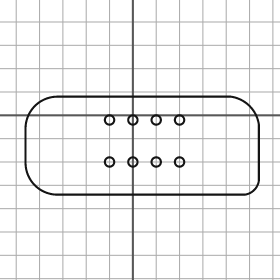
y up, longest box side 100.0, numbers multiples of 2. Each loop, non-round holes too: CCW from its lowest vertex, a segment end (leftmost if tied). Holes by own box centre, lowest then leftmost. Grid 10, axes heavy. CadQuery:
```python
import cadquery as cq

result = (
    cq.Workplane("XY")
    .moveTo(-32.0, -34.0)
    .lineTo(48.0, -34.0)
    .threePointArc((52.0, -32.0), (54.0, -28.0))
    .lineTo(54.0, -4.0)
    .threePointArc((50.0, 4.0), (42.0, 8.0))
    .lineTo(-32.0, 8.0)
    .threePointArc((-42.0, 4.0), (-46.0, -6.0))
    .lineTo(-46.0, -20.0)
    .threePointArc((-42.0, -30.0), (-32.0, -34.0))
    .close()
    .moveTo(-10.0, -20.0)
    .circle(2.0)
    .moveTo(0.0, -20.0)
    .circle(2.0)
    .moveTo(10.0, -20.0)
    .circle(2.0)
    .moveTo(20.0, -20.0)
    .circle(2.0)
    .moveTo(-10.0, -2.0)
    .circle(2.0)
    .moveTo(0.0, -2.0)
    .circle(2.0)
    .moveTo(10.0, -2.0)
    .circle(2.0)
    .moveTo(20.0, -2.0)
    .circle(2.0)
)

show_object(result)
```